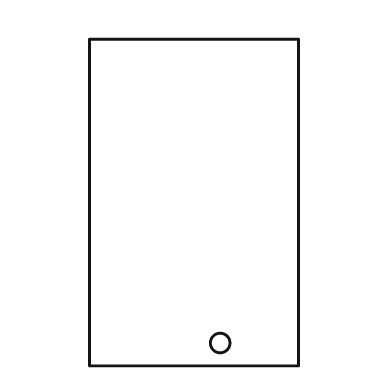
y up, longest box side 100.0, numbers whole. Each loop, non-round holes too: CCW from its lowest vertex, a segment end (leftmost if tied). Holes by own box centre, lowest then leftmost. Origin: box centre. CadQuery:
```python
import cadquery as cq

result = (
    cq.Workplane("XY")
    .moveTo(-32.0, -50.0)
    .lineTo(32.0, -50.0)
    .lineTo(32.0, 50.0)
    .lineTo(-32.0, 50.0)
    .close()
    .moveTo(8.0, -43.0)
    .circle(3.0)
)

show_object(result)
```